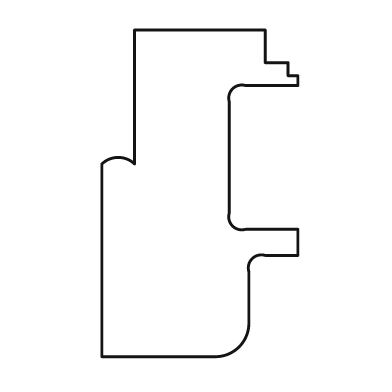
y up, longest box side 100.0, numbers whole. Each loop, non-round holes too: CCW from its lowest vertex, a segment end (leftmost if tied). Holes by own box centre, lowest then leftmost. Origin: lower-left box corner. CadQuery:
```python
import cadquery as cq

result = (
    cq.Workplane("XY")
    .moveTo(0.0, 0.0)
    .lineTo(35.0, 0.0)
    .threePointArc((42.0, 3.0), (45.0, 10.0))
    .lineTo(45.0, 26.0)
    .threePointArc((46.0, 30.0), (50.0, 31.0))
    .lineTo(60.0, 31.0)
    .lineTo(60.0, 39.0)
    .lineTo(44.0, 39.0)
    .threePointArc((40.0, 40.0), (39.0, 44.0))
    .lineTo(39.0, 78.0)
    .threePointArc((40.0, 82.0), (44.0, 83.0))
    .lineTo(60.0, 83.0)
    .lineTo(60.0, 86.0)
    .lineTo(57.0, 86.0)
    .lineTo(57.0, 90.0)
    .lineTo(50.0, 90.0)
    .lineTo(50.0, 100.0)
    .lineTo(10.0, 100.0)
    .lineTo(10.0, 59.0)
    .threePointArc((5.0, 61.0), (0.0, 59.0))
    .close()
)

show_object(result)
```